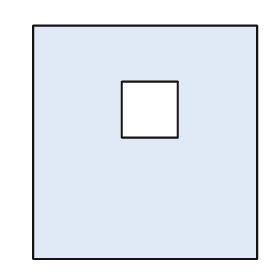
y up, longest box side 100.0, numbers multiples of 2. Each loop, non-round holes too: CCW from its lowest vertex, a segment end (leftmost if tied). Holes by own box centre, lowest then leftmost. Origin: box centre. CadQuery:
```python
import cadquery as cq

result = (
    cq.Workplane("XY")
    .moveTo(-48.0, -50.0)
    .lineTo(48.0, -50.0)
    .lineTo(48.0, 50.0)
    .lineTo(-48.0, 50.0)
    .close()
    .moveTo(-10.0, 2.0)
    .lineTo(14.0, 2.0)
    .lineTo(14.0, 26.0)
    .lineTo(-10.0, 26.0)
    .close()
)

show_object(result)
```